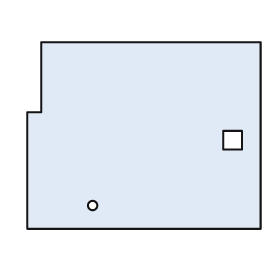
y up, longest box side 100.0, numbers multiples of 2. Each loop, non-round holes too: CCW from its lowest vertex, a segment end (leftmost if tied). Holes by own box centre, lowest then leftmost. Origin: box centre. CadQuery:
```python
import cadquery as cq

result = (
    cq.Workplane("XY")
    .moveTo(-50.0, -40.0)
    .lineTo(50.0, -40.0)
    .lineTo(50.0, 40.0)
    .lineTo(-44.0, 40.0)
    .lineTo(-44.0, 10.0)
    .lineTo(-50.0, 10.0)
    .close()
    .moveTo(-22.0, -30.0)
    .circle(2.0)
    .moveTo(34.0, -6.0)
    .lineTo(42.0, -6.0)
    .lineTo(42.0, 2.0)
    .lineTo(34.0, 2.0)
    .close()
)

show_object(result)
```